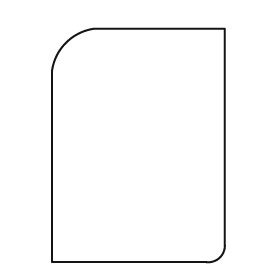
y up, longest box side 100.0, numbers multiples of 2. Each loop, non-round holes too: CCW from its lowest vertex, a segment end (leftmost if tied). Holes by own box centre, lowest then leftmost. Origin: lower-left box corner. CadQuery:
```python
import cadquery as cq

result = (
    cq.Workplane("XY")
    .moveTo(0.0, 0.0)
    .lineTo(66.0, 0.0)
    .threePointArc((72.0, 2.0), (74.0, 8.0))
    .lineTo(74.0, 100.0)
    .lineTo(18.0, 100.0)
    .threePointArc((6.0, 94.0), (0.0, 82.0))
    .close()
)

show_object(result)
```